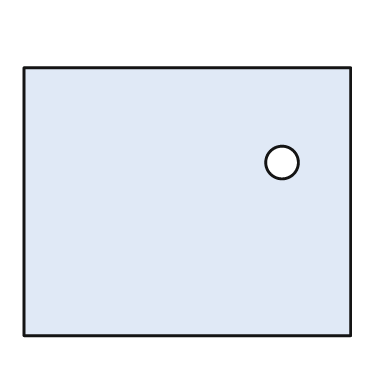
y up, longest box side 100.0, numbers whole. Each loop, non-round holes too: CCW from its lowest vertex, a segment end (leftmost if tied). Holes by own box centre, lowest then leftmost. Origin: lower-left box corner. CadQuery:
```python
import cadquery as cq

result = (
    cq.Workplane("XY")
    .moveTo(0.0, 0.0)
    .lineTo(100.0, 0.0)
    .lineTo(100.0, 82.0)
    .lineTo(0.0, 82.0)
    .close()
    .moveTo(79.0, 53.0)
    .circle(5.0)
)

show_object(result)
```